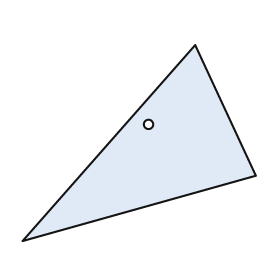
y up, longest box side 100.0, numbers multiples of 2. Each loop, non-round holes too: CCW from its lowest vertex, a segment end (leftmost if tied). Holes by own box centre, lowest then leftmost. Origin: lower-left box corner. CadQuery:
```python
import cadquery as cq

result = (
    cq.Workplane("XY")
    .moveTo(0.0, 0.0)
    .lineTo(100.0, 28.0)
    .lineTo(74.0, 84.0)
    .close()
    .moveTo(54.0, 50.0)
    .circle(2.0)
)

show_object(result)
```